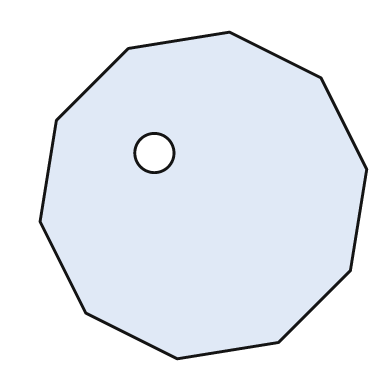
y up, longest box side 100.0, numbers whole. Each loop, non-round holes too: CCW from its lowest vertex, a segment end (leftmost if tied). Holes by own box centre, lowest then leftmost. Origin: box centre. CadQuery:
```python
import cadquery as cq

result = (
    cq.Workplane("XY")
    .moveTo(-8.0, -50.0)
    .lineTo(23.0, -45.0)
    .lineTo(45.0, -23.0)
    .lineTo(50.0, 8.0)
    .lineTo(36.0, 36.0)
    .lineTo(8.0, 50.0)
    .lineTo(-23.0, 45.0)
    .lineTo(-45.0, 23.0)
    .lineTo(-50.0, -8.0)
    .lineTo(-36.0, -36.0)
    .close()
    .moveTo(-15.0, 13.0)
    .circle(6.0)
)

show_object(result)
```